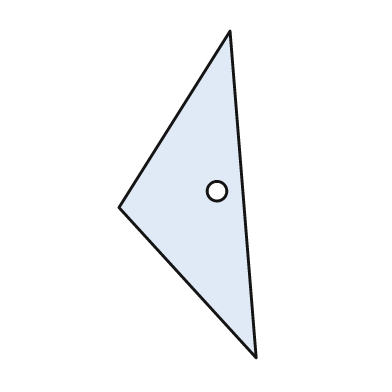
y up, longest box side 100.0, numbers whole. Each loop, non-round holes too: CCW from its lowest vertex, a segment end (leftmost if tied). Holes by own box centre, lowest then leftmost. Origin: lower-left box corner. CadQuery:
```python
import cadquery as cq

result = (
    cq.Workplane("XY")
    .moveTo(42.0, 0.0)
    .lineTo(34.0, 100.0)
    .lineTo(0.0, 46.0)
    .close()
    .moveTo(30.0, 51.0)
    .circle(3.0)
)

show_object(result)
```